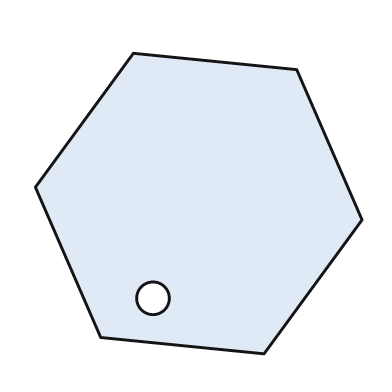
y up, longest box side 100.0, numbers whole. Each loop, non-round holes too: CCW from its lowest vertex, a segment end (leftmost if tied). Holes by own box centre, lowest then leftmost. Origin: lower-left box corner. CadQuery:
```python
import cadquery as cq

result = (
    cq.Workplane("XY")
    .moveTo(70.0, 0.0)
    .lineTo(100.0, 41.0)
    .lineTo(80.0, 87.0)
    .lineTo(30.0, 92.0)
    .lineTo(0.0, 51.0)
    .lineTo(20.0, 5.0)
    .close()
    .moveTo(36.0, 17.0)
    .circle(5.0)
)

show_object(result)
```